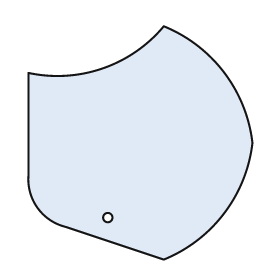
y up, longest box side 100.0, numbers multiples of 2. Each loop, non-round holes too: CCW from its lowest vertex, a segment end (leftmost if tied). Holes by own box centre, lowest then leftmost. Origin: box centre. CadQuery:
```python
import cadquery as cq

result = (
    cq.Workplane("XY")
    .moveTo(10.0, -50.0)
    .threePointArc((36.0, -30.0), (48.0, 0.0))
    .threePointArc((36.0, 30.0), (10.0, 50.0))
    .threePointArc((-16.0, 32.0), (-48.0, 30.0))
    .lineTo(-48.0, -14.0)
    .threePointArc((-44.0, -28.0), (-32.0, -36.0))
    .close()
    .moveTo(-14.0, -32.0)
    .circle(2.0)
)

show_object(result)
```